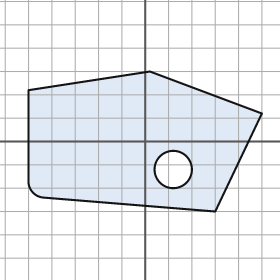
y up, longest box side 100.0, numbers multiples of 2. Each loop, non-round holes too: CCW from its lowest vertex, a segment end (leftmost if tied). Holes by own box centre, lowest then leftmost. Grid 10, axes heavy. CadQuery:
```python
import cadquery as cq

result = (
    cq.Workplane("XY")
    .moveTo(30.0, -30.0)
    .lineTo(50.0, 12.0)
    .lineTo(2.0, 30.0)
    .lineTo(-50.0, 22.0)
    .lineTo(-50.0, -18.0)
    .threePointArc((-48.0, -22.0), (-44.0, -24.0))
    .close()
    .moveTo(12.0, -12.0)
    .circle(8.0)
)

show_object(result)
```